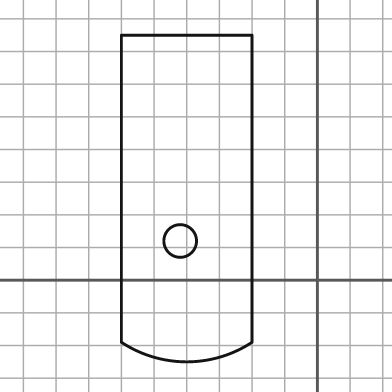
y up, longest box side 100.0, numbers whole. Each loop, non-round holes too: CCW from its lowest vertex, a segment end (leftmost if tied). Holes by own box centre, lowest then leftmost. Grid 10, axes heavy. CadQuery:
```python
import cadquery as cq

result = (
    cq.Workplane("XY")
    .moveTo(-60.0, -19.0)
    .threePointArc((-40.0, -25.0), (-20.0, -19.0))
    .lineTo(-20.0, 75.0)
    .lineTo(-60.0, 75.0)
    .close()
    .moveTo(-42.0, 12.0)
    .circle(5.0)
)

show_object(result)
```